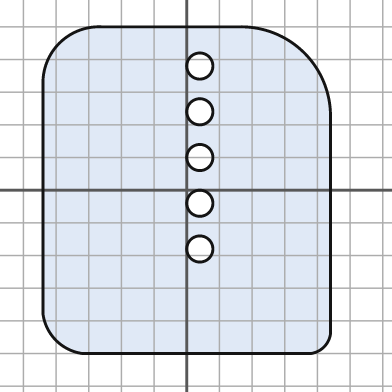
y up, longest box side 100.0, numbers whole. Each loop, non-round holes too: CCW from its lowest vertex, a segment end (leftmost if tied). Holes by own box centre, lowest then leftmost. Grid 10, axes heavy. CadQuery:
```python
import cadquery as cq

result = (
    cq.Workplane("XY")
    .moveTo(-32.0, -50.0)
    .lineTo(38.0, -50.0)
    .threePointArc((42.0, -48.0), (44.0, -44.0))
    .lineTo(44.0, 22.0)
    .threePointArc((36.0, 42.0), (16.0, 50.0))
    .lineTo(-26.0, 50.0)
    .threePointArc((-39.0, 45.0), (-44.0, 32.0))
    .lineTo(-44.0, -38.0)
    .threePointArc((-40.0, -46.0), (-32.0, -50.0))
    .close()
    .moveTo(4.0, -18.0)
    .circle(4.0)
    .moveTo(4.0, -4.0)
    .circle(4.0)
    .moveTo(4.0, 10.0)
    .circle(4.0)
    .moveTo(4.0, 24.0)
    .circle(4.0)
    .moveTo(4.0, 38.0)
    .circle(4.0)
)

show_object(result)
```